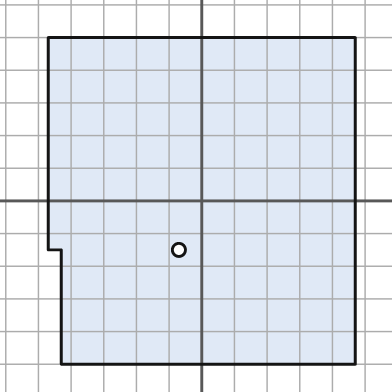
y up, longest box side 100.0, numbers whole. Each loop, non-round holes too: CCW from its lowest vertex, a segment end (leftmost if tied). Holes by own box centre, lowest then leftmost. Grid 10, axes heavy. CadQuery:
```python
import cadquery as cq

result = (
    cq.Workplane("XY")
    .moveTo(-43.0, -50.0)
    .lineTo(47.0, -50.0)
    .lineTo(47.0, 50.0)
    .lineTo(-47.0, 50.0)
    .lineTo(-47.0, -15.0)
    .lineTo(-43.0, -15.0)
    .close()
    .moveTo(-7.0, -15.0)
    .circle(2.0)
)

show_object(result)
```